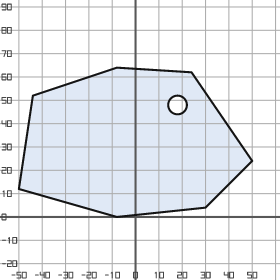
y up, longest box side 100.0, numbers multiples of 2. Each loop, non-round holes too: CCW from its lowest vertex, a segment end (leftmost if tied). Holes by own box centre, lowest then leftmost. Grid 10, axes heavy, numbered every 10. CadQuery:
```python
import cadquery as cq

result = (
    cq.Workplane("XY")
    .moveTo(-8.0, 0.0)
    .lineTo(30.0, 4.0)
    .lineTo(50.0, 24.0)
    .lineTo(24.0, 62.0)
    .lineTo(-8.0, 64.0)
    .lineTo(-44.0, 52.0)
    .lineTo(-50.0, 12.0)
    .close()
    .moveTo(18.0, 48.0)
    .circle(4.0)
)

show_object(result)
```